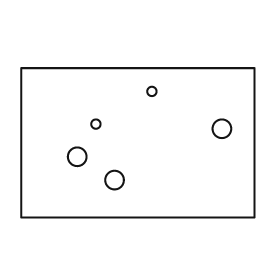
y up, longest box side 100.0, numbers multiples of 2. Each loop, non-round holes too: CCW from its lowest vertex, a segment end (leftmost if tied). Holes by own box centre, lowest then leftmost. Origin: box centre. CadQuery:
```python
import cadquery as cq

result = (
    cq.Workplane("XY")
    .moveTo(-50.0, -32.0)
    .lineTo(50.0, -32.0)
    .lineTo(50.0, 32.0)
    .lineTo(-50.0, 32.0)
    .close()
    .moveTo(-10.0, -16.0)
    .circle(4.0)
    .moveTo(-26.0, -6.0)
    .circle(4.0)
    .moveTo(36.0, 6.0)
    .circle(4.0)
    .moveTo(-18.0, 8.0)
    .circle(2.0)
    .moveTo(6.0, 22.0)
    .circle(2.0)
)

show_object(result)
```